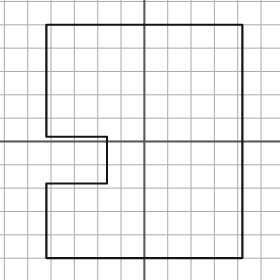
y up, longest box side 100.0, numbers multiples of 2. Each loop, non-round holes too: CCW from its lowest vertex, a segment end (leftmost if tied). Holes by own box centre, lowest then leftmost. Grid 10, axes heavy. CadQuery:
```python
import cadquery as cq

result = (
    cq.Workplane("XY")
    .moveTo(-42.0, -50.0)
    .lineTo(42.0, -50.0)
    .lineTo(42.0, 50.0)
    .lineTo(-42.0, 50.0)
    .lineTo(-42.0, 2.0)
    .lineTo(-16.0, 2.0)
    .lineTo(-16.0, -18.0)
    .lineTo(-42.0, -18.0)
    .close()
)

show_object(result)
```